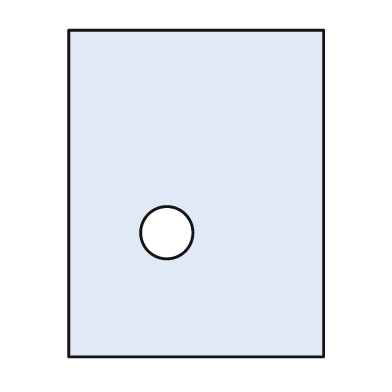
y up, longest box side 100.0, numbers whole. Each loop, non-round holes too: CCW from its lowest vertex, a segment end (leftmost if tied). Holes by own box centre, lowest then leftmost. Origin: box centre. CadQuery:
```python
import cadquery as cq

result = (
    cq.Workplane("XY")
    .moveTo(-39.0, -50.0)
    .lineTo(39.0, -50.0)
    .lineTo(39.0, 50.0)
    .lineTo(-39.0, 50.0)
    .close()
    .moveTo(-9.0, -12.0)
    .circle(8.0)
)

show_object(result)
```